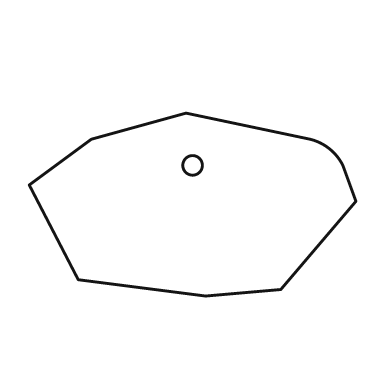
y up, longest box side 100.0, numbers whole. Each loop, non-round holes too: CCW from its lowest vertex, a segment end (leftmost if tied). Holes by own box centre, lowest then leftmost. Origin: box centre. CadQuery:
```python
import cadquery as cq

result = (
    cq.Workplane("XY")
    .moveTo(4.0, -28.0)
    .lineTo(27.0, -26.0)
    .lineTo(50.0, 1.0)
    .lineTo(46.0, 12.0)
    .threePointArc((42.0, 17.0), (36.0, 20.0))
    .lineTo(-2.0, 28.0)
    .lineTo(-31.0, 20.0)
    .lineTo(-50.0, 6.0)
    .lineTo(-35.0, -23.0)
    .close()
    .moveTo(0.0, 12.0)
    .circle(3.0)
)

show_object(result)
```